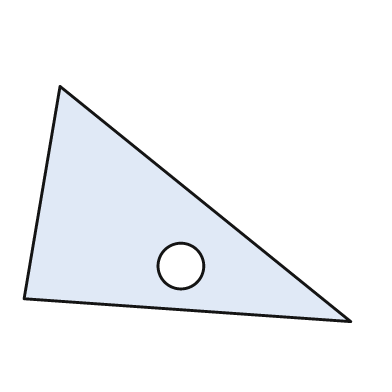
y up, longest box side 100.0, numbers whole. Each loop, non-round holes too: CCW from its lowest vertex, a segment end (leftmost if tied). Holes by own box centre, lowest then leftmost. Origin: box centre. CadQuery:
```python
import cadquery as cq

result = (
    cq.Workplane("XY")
    .moveTo(50.0, -36.0)
    .lineTo(-39.0, 36.0)
    .lineTo(-50.0, -29.0)
    .close()
    .moveTo(-2.0, -19.0)
    .circle(7.0)
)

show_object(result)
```